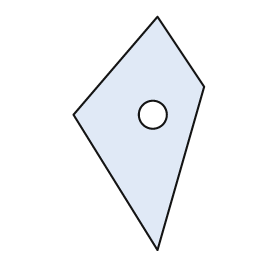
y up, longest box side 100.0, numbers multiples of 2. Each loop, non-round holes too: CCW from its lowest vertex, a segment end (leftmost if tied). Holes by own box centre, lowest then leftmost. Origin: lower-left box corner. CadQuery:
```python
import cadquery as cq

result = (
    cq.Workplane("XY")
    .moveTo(36.0, 0.0)
    .lineTo(56.0, 70.0)
    .lineTo(36.0, 100.0)
    .lineTo(0.0, 58.0)
    .close()
    .moveTo(34.0, 58.0)
    .circle(6.0)
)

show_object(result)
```